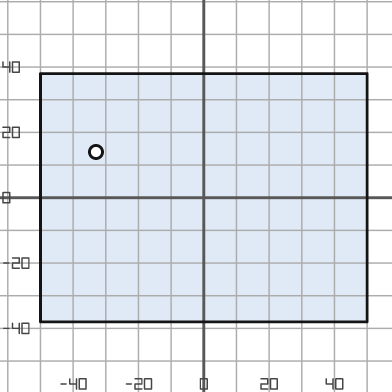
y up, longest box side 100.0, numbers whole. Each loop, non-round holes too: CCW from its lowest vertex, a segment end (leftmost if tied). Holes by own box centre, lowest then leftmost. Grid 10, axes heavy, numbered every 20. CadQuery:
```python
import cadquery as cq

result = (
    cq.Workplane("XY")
    .moveTo(-50.0, -38.0)
    .lineTo(50.0, -38.0)
    .lineTo(50.0, 38.0)
    .lineTo(-50.0, 38.0)
    .close()
    .moveTo(-33.0, 14.0)
    .circle(2.0)
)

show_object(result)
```